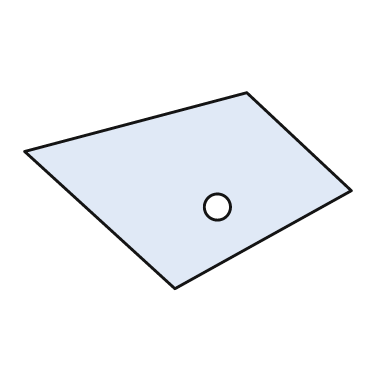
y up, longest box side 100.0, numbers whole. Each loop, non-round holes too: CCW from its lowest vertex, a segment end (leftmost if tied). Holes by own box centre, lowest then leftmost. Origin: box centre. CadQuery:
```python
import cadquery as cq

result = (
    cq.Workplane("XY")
    .moveTo(-4.0, -30.0)
    .lineTo(50.0, 0.0)
    .lineTo(18.0, 30.0)
    .lineTo(-50.0, 12.0)
    .close()
    .moveTo(9.0, -5.0)
    .circle(4.0)
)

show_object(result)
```